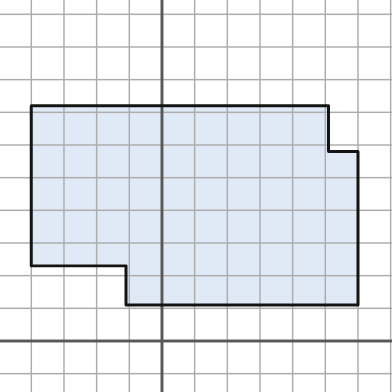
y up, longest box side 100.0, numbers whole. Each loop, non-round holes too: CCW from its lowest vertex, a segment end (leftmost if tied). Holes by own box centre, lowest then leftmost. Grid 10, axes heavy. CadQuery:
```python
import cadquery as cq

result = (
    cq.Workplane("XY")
    .moveTo(-11.0, 11.0)
    .lineTo(60.0, 11.0)
    .lineTo(60.0, 58.0)
    .lineTo(51.0, 58.0)
    .lineTo(51.0, 72.0)
    .lineTo(-40.0, 72.0)
    .lineTo(-40.0, 23.0)
    .lineTo(-11.0, 23.0)
    .close()
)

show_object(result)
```